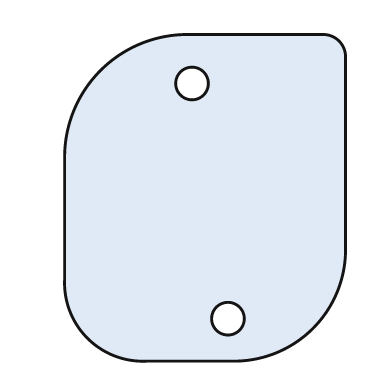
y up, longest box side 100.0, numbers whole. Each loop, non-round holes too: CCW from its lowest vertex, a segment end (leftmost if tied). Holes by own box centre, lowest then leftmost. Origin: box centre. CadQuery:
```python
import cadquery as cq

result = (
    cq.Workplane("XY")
    .moveTo(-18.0, -50.0)
    .lineTo(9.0, -50.0)
    .threePointArc((33.0, -40.0), (43.0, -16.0))
    .lineTo(43.0, 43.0)
    .threePointArc((41.0, 48.0), (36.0, 50.0))
    .lineTo(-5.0, 50.0)
    .threePointArc((-32.0, 39.0), (-43.0, 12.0))
    .lineTo(-43.0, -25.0)
    .threePointArc((-36.0, -43.0), (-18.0, -50.0))
    .close()
    .moveTo(7.0, -37.0)
    .circle(5.0)
    .moveTo(-4.0, 35.0)
    .circle(5.0)
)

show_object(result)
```